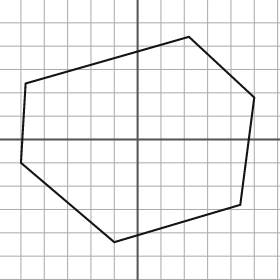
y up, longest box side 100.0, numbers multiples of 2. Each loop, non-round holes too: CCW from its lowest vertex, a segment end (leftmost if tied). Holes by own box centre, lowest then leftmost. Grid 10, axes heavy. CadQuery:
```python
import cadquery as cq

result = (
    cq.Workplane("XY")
    .moveTo(-10.0, -44.0)
    .lineTo(44.0, -28.0)
    .lineTo(50.0, 18.0)
    .lineTo(22.0, 44.0)
    .lineTo(-48.0, 24.0)
    .lineTo(-50.0, -10.0)
    .close()
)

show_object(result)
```